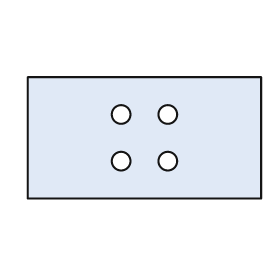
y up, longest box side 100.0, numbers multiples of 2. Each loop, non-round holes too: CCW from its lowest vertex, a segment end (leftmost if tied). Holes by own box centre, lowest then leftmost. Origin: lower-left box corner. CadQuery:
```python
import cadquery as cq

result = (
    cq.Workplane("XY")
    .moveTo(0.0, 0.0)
    .lineTo(100.0, 0.0)
    .lineTo(100.0, 52.0)
    .lineTo(0.0, 52.0)
    .close()
    .moveTo(40.0, 16.0)
    .circle(4.0)
    .moveTo(60.0, 16.0)
    .circle(4.0)
    .moveTo(40.0, 36.0)
    .circle(4.0)
    .moveTo(60.0, 36.0)
    .circle(4.0)
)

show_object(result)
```